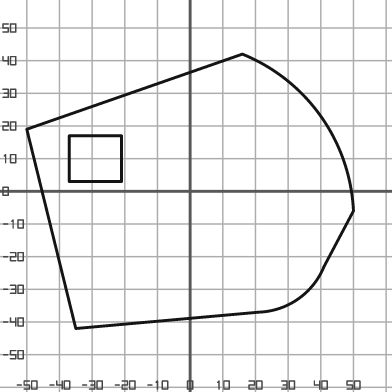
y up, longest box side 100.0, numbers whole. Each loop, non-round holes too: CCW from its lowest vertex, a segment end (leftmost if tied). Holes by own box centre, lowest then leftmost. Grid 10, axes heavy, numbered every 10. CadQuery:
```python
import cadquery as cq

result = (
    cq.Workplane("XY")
    .moveTo(-35.0, -42.0)
    .lineTo(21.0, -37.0)
    .threePointArc((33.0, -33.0), (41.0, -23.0))
    .lineTo(50.0, -6.0)
    .threePointArc((40.0, 23.0), (16.0, 42.0))
    .lineTo(-50.0, 19.0)
    .close()
    .moveTo(-37.0, 3.0)
    .lineTo(-21.0, 3.0)
    .lineTo(-21.0, 17.0)
    .lineTo(-37.0, 17.0)
    .close()
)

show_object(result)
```